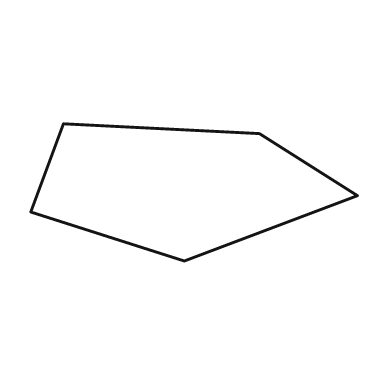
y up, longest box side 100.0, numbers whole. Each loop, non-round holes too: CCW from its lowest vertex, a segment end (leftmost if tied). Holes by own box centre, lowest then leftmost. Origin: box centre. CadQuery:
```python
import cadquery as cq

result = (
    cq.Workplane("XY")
    .moveTo(-3.0, -21.0)
    .lineTo(50.0, -1.0)
    .lineTo(20.0, 18.0)
    .lineTo(-40.0, 21.0)
    .lineTo(-50.0, -6.0)
    .close()
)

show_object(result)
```